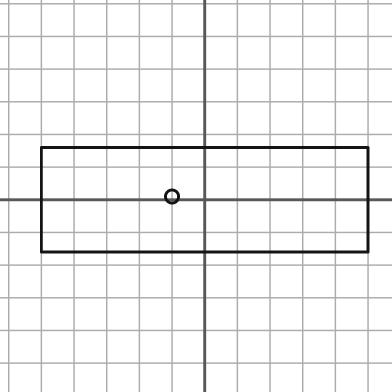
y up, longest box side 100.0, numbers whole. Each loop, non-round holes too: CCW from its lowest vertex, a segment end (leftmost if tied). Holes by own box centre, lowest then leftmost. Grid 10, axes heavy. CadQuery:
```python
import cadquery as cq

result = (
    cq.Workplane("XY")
    .moveTo(-50.0, -16.0)
    .lineTo(50.0, -16.0)
    .lineTo(50.0, 16.0)
    .lineTo(-50.0, 16.0)
    .close()
    .moveTo(-10.0, 1.0)
    .circle(2.0)
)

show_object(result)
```